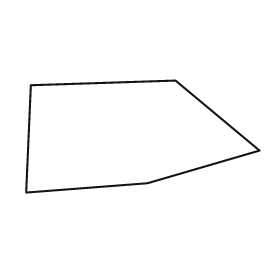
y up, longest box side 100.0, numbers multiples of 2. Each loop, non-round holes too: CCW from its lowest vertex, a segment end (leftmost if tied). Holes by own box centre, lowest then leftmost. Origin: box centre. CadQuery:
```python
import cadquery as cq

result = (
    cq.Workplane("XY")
    .moveTo(-50.0, -24.0)
    .lineTo(2.0, -20.0)
    .lineTo(50.0, -6.0)
    .lineTo(14.0, 24.0)
    .lineTo(-48.0, 22.0)
    .close()
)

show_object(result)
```